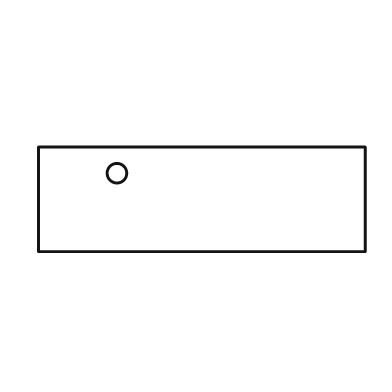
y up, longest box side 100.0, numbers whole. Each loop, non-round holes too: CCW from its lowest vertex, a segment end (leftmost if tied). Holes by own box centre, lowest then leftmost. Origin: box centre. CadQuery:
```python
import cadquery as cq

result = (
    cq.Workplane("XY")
    .moveTo(-50.0, -16.0)
    .lineTo(50.0, -16.0)
    .lineTo(50.0, 16.0)
    .lineTo(-50.0, 16.0)
    .close()
    .moveTo(-26.0, 8.0)
    .circle(3.0)
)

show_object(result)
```